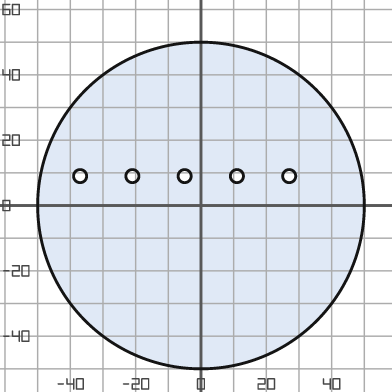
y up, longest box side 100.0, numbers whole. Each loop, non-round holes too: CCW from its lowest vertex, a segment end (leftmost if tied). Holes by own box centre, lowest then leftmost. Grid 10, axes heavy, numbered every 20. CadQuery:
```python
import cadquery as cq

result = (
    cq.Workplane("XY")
    .moveTo(0.0, 0.0)
    .circle(50.0)
    .moveTo(-37.0, 9.0)
    .circle(2.0)
    .moveTo(-21.0, 9.0)
    .circle(2.0)
    .moveTo(-5.0, 9.0)
    .circle(2.0)
    .moveTo(11.0, 9.0)
    .circle(2.0)
    .moveTo(27.0, 9.0)
    .circle(2.0)
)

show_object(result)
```